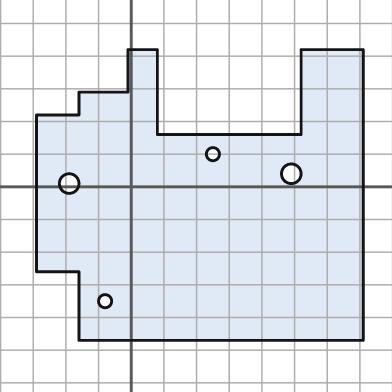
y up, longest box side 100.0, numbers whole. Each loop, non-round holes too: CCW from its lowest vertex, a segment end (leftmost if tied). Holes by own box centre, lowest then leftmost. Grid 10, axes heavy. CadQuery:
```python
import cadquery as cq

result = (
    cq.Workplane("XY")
    .moveTo(-16.0, -47.0)
    .lineTo(71.0, -47.0)
    .lineTo(71.0, 42.0)
    .lineTo(52.0, 42.0)
    .lineTo(52.0, 16.0)
    .lineTo(8.0, 16.0)
    .lineTo(8.0, 42.0)
    .lineTo(-1.0, 42.0)
    .lineTo(-1.0, 29.0)
    .lineTo(-16.0, 29.0)
    .lineTo(-16.0, 22.0)
    .lineTo(-29.0, 22.0)
    .lineTo(-29.0, -26.0)
    .lineTo(-16.0, -26.0)
    .close()
    .moveTo(-8.0, -35.0)
    .circle(2.0)
    .moveTo(-19.0, 1.0)
    .circle(3.0)
    .moveTo(49.0, 4.0)
    .circle(3.0)
    .moveTo(25.0, 10.0)
    .circle(2.0)
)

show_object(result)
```